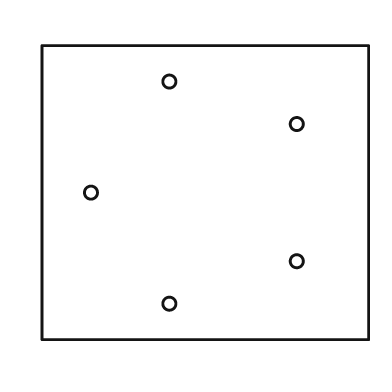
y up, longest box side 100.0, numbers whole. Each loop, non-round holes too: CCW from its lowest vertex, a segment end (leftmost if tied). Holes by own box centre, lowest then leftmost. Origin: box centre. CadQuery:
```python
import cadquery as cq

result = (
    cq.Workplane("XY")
    .moveTo(-50.0, -45.0)
    .lineTo(50.0, -45.0)
    .lineTo(50.0, 45.0)
    .lineTo(-50.0, 45.0)
    .close()
    .moveTo(-11.0, -34.0)
    .circle(2.0)
    .moveTo(28.0, -21.0)
    .circle(2.0)
    .moveTo(-35.0, 0.0)
    .circle(2.0)
    .moveTo(28.0, 21.0)
    .circle(2.0)
    .moveTo(-11.0, 34.0)
    .circle(2.0)
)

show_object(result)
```